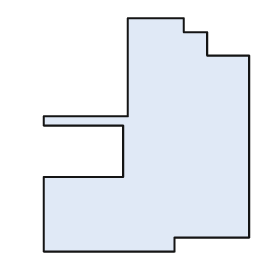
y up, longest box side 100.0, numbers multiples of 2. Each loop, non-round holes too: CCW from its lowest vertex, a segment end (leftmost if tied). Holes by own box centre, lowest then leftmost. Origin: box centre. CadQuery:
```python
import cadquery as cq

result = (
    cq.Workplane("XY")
    .moveTo(-44.0, -50.0)
    .lineTo(12.0, -50.0)
    .lineTo(12.0, -44.0)
    .lineTo(44.0, -44.0)
    .lineTo(44.0, 34.0)
    .lineTo(26.0, 34.0)
    .lineTo(26.0, 44.0)
    .lineTo(16.0, 44.0)
    .lineTo(16.0, 50.0)
    .lineTo(-8.0, 50.0)
    .lineTo(-8.0, 8.0)
    .lineTo(-44.0, 8.0)
    .lineTo(-44.0, 4.0)
    .lineTo(-10.0, 4.0)
    .lineTo(-10.0, -18.0)
    .lineTo(-44.0, -18.0)
    .close()
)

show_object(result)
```